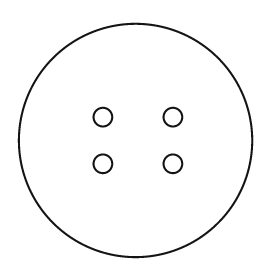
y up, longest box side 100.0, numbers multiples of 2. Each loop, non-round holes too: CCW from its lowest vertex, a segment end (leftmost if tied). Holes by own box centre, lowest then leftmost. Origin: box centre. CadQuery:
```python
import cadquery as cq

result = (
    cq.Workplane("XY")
    .moveTo(0.0, 0.0)
    .circle(50.0)
    .moveTo(-14.0, -10.0)
    .circle(4.0)
    .moveTo(16.0, -10.0)
    .circle(4.0)
    .moveTo(-14.0, 10.0)
    .circle(4.0)
    .moveTo(16.0, 10.0)
    .circle(4.0)
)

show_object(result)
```